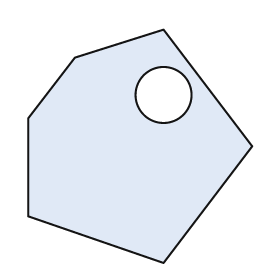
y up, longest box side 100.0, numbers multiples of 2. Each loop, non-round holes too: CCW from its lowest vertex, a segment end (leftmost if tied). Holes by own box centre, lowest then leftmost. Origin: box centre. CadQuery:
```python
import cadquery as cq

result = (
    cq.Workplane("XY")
    .moveTo(10.0, -50.0)
    .lineTo(48.0, 0.0)
    .lineTo(10.0, 50.0)
    .lineTo(-28.0, 38.0)
    .lineTo(-48.0, 12.0)
    .lineTo(-48.0, -30.0)
    .close()
    .moveTo(10.0, 22.0)
    .circle(12.0)
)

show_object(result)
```